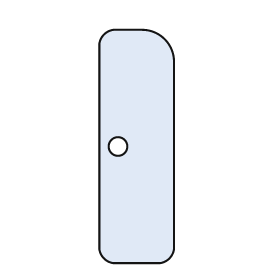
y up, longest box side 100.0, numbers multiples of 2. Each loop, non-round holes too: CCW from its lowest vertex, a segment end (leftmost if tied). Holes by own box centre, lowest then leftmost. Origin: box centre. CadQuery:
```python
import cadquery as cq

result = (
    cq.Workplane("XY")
    .moveTo(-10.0, -50.0)
    .lineTo(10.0, -50.0)
    .threePointArc((14.0, -48.0), (16.0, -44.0))
    .lineTo(16.0, 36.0)
    .threePointArc((12.0, 46.0), (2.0, 50.0))
    .lineTo(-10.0, 50.0)
    .threePointArc((-14.0, 48.0), (-16.0, 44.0))
    .lineTo(-16.0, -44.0)
    .threePointArc((-14.0, -48.0), (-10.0, -50.0))
    .close()
    .moveTo(-8.0, 0.0)
    .circle(4.0)
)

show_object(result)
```